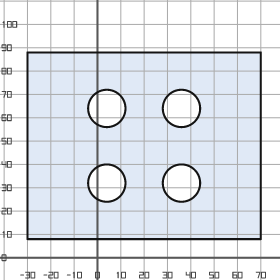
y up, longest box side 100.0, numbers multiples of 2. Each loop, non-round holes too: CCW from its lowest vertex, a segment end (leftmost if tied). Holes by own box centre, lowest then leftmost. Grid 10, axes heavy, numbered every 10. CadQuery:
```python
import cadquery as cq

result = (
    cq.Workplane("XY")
    .moveTo(-30.0, 8.0)
    .lineTo(70.0, 8.0)
    .lineTo(70.0, 88.0)
    .lineTo(-30.0, 88.0)
    .close()
    .moveTo(4.0, 32.0)
    .circle(8.0)
    .moveTo(36.0, 32.0)
    .circle(8.0)
    .moveTo(4.0, 64.0)
    .circle(8.0)
    .moveTo(36.0, 64.0)
    .circle(8.0)
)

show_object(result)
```